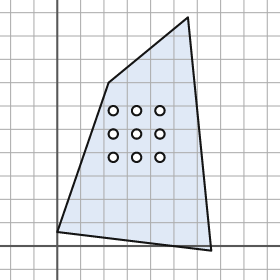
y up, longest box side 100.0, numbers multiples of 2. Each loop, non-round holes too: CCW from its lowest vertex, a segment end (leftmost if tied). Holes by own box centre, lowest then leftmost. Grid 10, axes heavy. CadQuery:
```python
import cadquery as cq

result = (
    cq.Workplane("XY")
    .moveTo(66.0, -2.0)
    .lineTo(56.0, 98.0)
    .lineTo(22.0, 70.0)
    .lineTo(0.0, 6.0)
    .close()
    .moveTo(24.0, 38.0)
    .circle(2.0)
    .moveTo(34.0, 38.0)
    .circle(2.0)
    .moveTo(44.0, 38.0)
    .circle(2.0)
    .moveTo(24.0, 48.0)
    .circle(2.0)
    .moveTo(34.0, 48.0)
    .circle(2.0)
    .moveTo(44.0, 48.0)
    .circle(2.0)
    .moveTo(24.0, 58.0)
    .circle(2.0)
    .moveTo(34.0, 58.0)
    .circle(2.0)
    .moveTo(44.0, 58.0)
    .circle(2.0)
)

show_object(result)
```